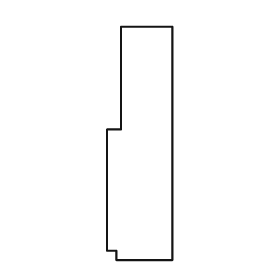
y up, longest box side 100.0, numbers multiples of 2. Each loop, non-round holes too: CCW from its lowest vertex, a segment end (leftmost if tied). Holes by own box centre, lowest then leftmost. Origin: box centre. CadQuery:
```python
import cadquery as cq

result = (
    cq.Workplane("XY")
    .moveTo(-10.0, -50.0)
    .lineTo(14.0, -50.0)
    .lineTo(14.0, 50.0)
    .lineTo(-8.0, 50.0)
    .lineTo(-8.0, 6.0)
    .lineTo(-14.0, 6.0)
    .lineTo(-14.0, -46.0)
    .lineTo(-10.0, -46.0)
    .close()
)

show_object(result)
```